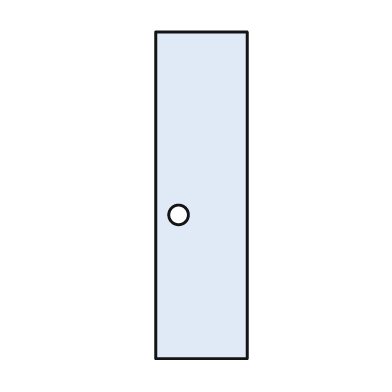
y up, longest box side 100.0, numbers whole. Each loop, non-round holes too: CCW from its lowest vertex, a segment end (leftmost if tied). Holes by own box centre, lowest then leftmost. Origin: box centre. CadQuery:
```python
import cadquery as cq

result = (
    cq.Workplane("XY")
    .moveTo(-14.0, -50.0)
    .lineTo(14.0, -50.0)
    .lineTo(14.0, 50.0)
    .lineTo(-14.0, 50.0)
    .close()
    .moveTo(-7.0, -6.0)
    .circle(3.0)
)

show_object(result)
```